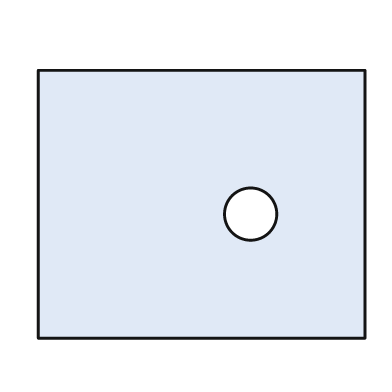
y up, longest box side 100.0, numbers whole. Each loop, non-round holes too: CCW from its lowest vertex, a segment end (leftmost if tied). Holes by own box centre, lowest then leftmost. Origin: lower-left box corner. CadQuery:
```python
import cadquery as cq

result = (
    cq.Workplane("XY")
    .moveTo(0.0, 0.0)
    .lineTo(100.0, 0.0)
    .lineTo(100.0, 82.0)
    .lineTo(0.0, 82.0)
    .close()
    .moveTo(65.0, 38.0)
    .circle(8.0)
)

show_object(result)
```